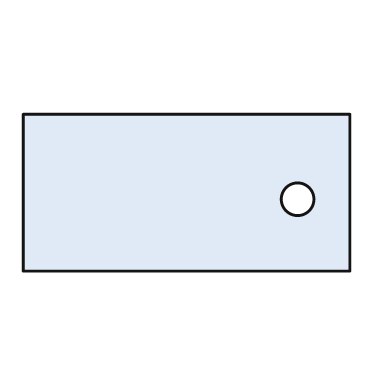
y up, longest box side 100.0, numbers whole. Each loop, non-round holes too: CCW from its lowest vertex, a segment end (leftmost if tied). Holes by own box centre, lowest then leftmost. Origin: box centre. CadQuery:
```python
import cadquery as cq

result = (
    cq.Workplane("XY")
    .moveTo(-50.0, -24.0)
    .lineTo(50.0, -24.0)
    .lineTo(50.0, 24.0)
    .lineTo(-50.0, 24.0)
    .close()
    .moveTo(34.0, -2.0)
    .circle(5.0)
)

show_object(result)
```